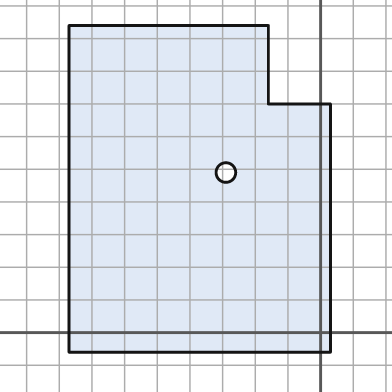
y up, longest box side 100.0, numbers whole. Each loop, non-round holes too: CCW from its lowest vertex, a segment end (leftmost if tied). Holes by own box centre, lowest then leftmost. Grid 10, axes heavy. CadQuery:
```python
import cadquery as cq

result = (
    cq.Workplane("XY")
    .moveTo(-77.0, -6.0)
    .lineTo(3.0, -6.0)
    .lineTo(3.0, 70.0)
    .lineTo(-16.0, 70.0)
    .lineTo(-16.0, 94.0)
    .lineTo(-77.0, 94.0)
    .close()
    .moveTo(-29.0, 49.0)
    .circle(3.0)
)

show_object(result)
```